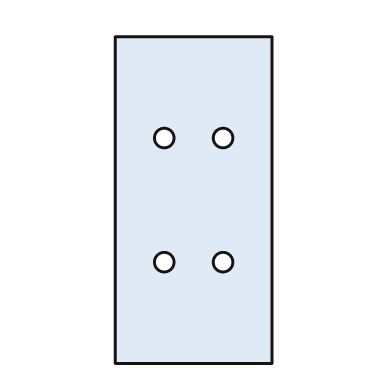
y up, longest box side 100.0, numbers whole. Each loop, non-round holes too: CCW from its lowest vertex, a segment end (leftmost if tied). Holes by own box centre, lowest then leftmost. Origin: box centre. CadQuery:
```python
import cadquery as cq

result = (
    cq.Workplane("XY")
    .moveTo(-24.0, -50.0)
    .lineTo(24.0, -50.0)
    .lineTo(24.0, 50.0)
    .lineTo(-24.0, 50.0)
    .close()
    .moveTo(-9.0, -19.0)
    .circle(3.0)
    .moveTo(9.0, -19.0)
    .circle(3.0)
    .moveTo(-9.0, 19.0)
    .circle(3.0)
    .moveTo(9.0, 19.0)
    .circle(3.0)
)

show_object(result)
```